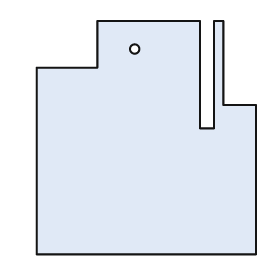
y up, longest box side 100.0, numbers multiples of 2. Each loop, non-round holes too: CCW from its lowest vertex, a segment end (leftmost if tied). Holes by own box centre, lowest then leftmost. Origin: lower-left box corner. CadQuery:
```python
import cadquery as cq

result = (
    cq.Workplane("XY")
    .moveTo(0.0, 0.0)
    .lineTo(94.0, 0.0)
    .lineTo(94.0, 64.0)
    .lineTo(80.0, 64.0)
    .lineTo(80.0, 100.0)
    .lineTo(76.0, 100.0)
    .lineTo(76.0, 54.0)
    .lineTo(70.0, 54.0)
    .lineTo(70.0, 100.0)
    .lineTo(26.0, 100.0)
    .lineTo(26.0, 80.0)
    .lineTo(0.0, 80.0)
    .close()
    .moveTo(42.0, 88.0)
    .circle(2.0)
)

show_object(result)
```